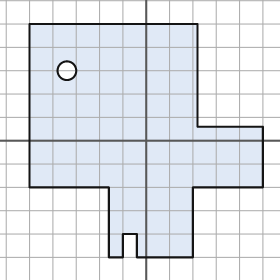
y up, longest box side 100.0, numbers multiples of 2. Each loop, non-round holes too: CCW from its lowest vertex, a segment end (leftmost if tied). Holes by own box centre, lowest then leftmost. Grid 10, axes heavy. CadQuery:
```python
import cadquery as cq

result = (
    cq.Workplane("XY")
    .moveTo(-16.0, -50.0)
    .lineTo(-10.0, -50.0)
    .lineTo(-10.0, -40.0)
    .lineTo(-4.0, -40.0)
    .lineTo(-4.0, -50.0)
    .lineTo(20.0, -50.0)
    .lineTo(20.0, -20.0)
    .lineTo(50.0, -20.0)
    .lineTo(50.0, 6.0)
    .lineTo(22.0, 6.0)
    .lineTo(22.0, 50.0)
    .lineTo(-50.0, 50.0)
    .lineTo(-50.0, -20.0)
    .lineTo(-16.0, -20.0)
    .close()
    .moveTo(-34.0, 30.0)
    .circle(4.0)
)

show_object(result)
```